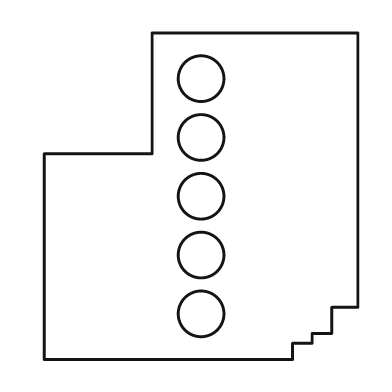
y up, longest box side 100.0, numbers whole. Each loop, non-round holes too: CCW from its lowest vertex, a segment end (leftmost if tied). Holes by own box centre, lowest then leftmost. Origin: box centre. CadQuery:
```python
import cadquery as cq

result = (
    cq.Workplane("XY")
    .moveTo(-48.0, -50.0)
    .lineTo(28.0, -50.0)
    .lineTo(28.0, -45.0)
    .lineTo(34.0, -45.0)
    .lineTo(34.0, -42.0)
    .lineTo(40.0, -42.0)
    .lineTo(40.0, -34.0)
    .lineTo(48.0, -34.0)
    .lineTo(48.0, 50.0)
    .lineTo(-15.0, 50.0)
    .lineTo(-15.0, 13.0)
    .lineTo(-48.0, 13.0)
    .close()
    .moveTo(0.0, -36.0)
    .circle(7.0)
    .moveTo(0.0, -18.0)
    .circle(7.0)
    .moveTo(0.0, 0.0)
    .circle(7.0)
    .moveTo(0.0, 18.0)
    .circle(7.0)
    .moveTo(0.0, 36.0)
    .circle(7.0)
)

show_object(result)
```